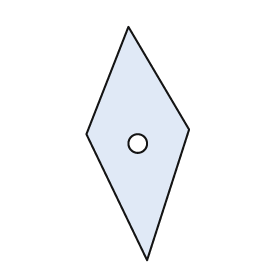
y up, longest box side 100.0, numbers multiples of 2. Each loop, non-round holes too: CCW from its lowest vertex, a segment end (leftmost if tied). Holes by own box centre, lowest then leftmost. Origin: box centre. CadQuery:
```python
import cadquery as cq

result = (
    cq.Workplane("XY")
    .moveTo(4.0, -50.0)
    .lineTo(22.0, 6.0)
    .lineTo(-4.0, 50.0)
    .lineTo(-22.0, 4.0)
    .close()
    .moveTo(0.0, 0.0)
    .circle(4.0)
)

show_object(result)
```